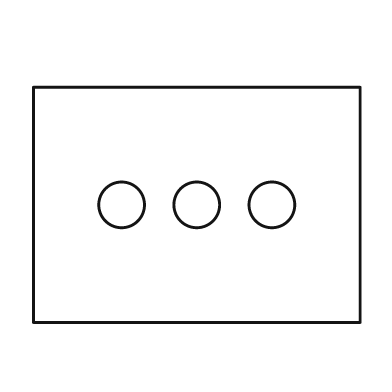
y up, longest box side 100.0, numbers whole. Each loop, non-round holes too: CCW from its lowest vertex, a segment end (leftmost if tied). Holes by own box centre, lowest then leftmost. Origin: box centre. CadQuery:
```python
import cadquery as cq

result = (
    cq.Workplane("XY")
    .moveTo(-50.0, -36.0)
    .lineTo(50.0, -36.0)
    .lineTo(50.0, 36.0)
    .lineTo(-50.0, 36.0)
    .close()
    .moveTo(-23.0, 0.0)
    .circle(7.0)
    .moveTo(0.0, 0.0)
    .circle(7.0)
    .moveTo(23.0, 0.0)
    .circle(7.0)
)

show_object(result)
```